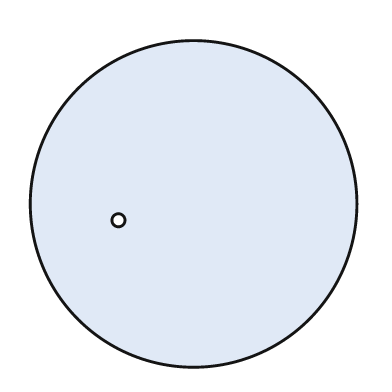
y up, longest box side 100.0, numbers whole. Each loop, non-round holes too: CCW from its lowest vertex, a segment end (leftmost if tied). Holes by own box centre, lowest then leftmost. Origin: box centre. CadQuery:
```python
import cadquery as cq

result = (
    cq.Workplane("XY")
    .moveTo(0.0, 0.0)
    .circle(50.0)
    .moveTo(-23.0, -5.0)
    .circle(2.0)
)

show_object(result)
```